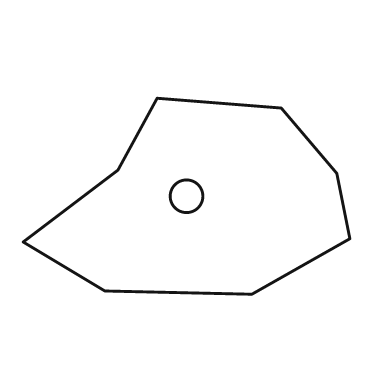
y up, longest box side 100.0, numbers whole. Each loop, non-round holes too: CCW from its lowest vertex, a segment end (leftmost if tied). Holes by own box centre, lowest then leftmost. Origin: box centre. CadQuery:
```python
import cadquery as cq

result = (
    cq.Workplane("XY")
    .moveTo(20.0, -30.0)
    .lineTo(50.0, -13.0)
    .lineTo(46.0, 7.0)
    .lineTo(29.0, 27.0)
    .lineTo(-9.0, 30.0)
    .lineTo(-21.0, 8.0)
    .lineTo(-50.0, -14.0)
    .lineTo(-25.0, -29.0)
    .close()
    .moveTo(0.0, 0.0)
    .circle(5.0)
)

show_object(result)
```